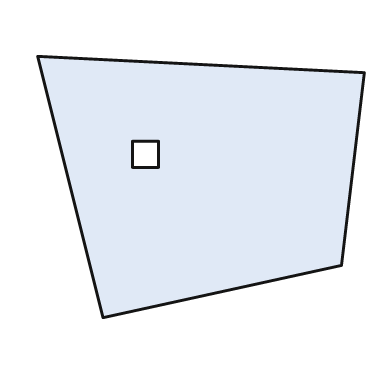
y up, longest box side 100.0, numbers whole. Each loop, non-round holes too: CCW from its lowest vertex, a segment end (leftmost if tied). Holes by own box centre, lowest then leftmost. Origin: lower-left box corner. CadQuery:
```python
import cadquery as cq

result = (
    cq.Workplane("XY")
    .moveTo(20.0, 0.0)
    .lineTo(93.0, 16.0)
    .lineTo(100.0, 75.0)
    .lineTo(0.0, 80.0)
    .close()
    .moveTo(29.0, 46.0)
    .lineTo(37.0, 46.0)
    .lineTo(37.0, 54.0)
    .lineTo(29.0, 54.0)
    .close()
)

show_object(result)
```